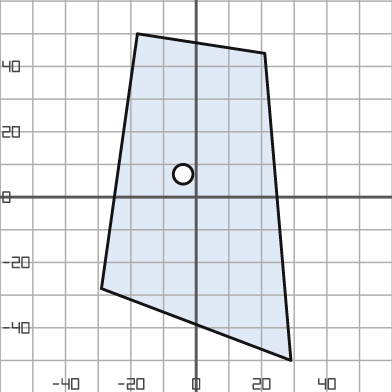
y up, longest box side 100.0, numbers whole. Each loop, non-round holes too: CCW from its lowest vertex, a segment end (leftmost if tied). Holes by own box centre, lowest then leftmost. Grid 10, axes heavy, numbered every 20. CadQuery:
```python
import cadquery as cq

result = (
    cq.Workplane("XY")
    .moveTo(29.0, -50.0)
    .lineTo(21.0, 44.0)
    .lineTo(-18.0, 50.0)
    .lineTo(-29.0, -28.0)
    .close()
    .moveTo(-4.0, 7.0)
    .circle(3.0)
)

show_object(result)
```